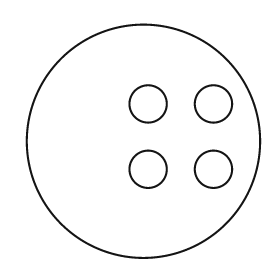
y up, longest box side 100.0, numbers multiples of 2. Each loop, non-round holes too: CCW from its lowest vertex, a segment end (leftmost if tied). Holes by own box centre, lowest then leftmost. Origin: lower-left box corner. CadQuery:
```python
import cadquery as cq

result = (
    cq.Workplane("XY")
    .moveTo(50.0, 50.0)
    .circle(50.0)
    .moveTo(52.0, 38.0)
    .circle(8.0)
    .moveTo(80.0, 38.0)
    .circle(8.0)
    .moveTo(52.0, 66.0)
    .circle(8.0)
    .moveTo(80.0, 66.0)
    .circle(8.0)
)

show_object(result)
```